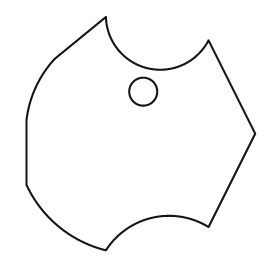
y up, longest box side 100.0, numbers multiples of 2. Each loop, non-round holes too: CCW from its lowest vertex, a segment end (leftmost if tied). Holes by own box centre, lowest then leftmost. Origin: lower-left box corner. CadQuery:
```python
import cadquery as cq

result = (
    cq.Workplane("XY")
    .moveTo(34.0, 0.0)
    .threePointArc((54.0, 14.0), (78.0, 10.0))
    .lineTo(98.0, 50.0)
    .lineTo(78.0, 90.0)
    .threePointArc((52.0, 78.0), (34.0, 100.0))
    .lineTo(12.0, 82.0)
    .threePointArc((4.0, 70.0), (0.0, 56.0))
    .lineTo(0.0, 28.0)
    .threePointArc((14.0, 10.0), (34.0, 0.0))
    .close()
    .moveTo(50.0, 68.0)
    .circle(6.0)
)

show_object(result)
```